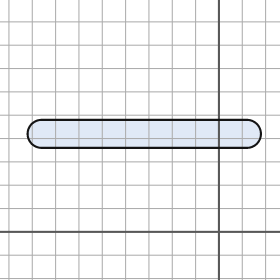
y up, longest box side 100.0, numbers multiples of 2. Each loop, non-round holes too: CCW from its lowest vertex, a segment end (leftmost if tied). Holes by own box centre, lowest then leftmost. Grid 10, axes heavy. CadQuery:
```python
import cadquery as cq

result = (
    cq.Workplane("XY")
    .moveTo(-76.0, 36.0)
    .lineTo(12.0, 36.0)
    .threePointArc((18.0, 42.0), (12.0, 48.0))
    .lineTo(-76.0, 48.0)
    .threePointArc((-82.0, 42.0), (-76.0, 36.0))
    .close()
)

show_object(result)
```